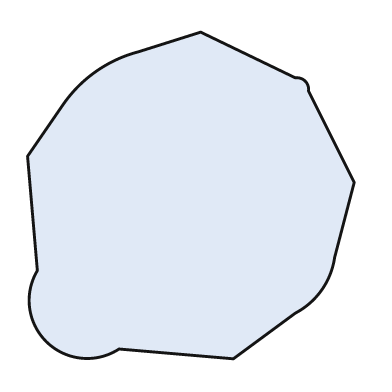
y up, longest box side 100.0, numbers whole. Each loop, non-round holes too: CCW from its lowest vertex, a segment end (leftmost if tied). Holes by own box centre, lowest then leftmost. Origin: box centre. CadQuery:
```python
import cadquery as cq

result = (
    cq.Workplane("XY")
    .moveTo(13.0, -50.0)
    .lineTo(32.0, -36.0)
    .threePointArc((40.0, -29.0), (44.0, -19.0))
    .lineTo(50.0, 4.0)
    .lineTo(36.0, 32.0)
    .threePointArc((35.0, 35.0), (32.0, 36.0))
    .lineTo(3.0, 50.0)
    .lineTo(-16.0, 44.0)
    .threePointArc((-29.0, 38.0), (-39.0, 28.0))
    .lineTo(-50.0, 12.0)
    .lineTo(-47.0, -23.0)
    .threePointArc((-44.0, -45.0), (-22.0, -47.0))
    .close()
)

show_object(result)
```